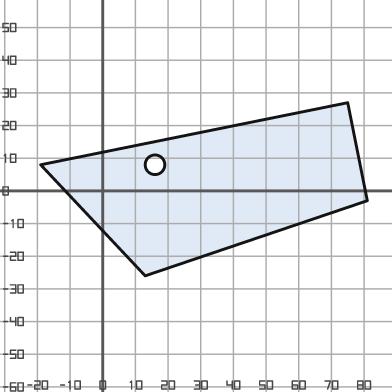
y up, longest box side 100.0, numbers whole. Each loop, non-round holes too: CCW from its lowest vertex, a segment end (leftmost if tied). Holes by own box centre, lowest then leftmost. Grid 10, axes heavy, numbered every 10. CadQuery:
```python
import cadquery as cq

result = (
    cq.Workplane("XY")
    .moveTo(13.0, -26.0)
    .lineTo(81.0, -3.0)
    .lineTo(75.0, 27.0)
    .lineTo(-19.0, 8.0)
    .close()
    .moveTo(16.0, 8.0)
    .circle(3.0)
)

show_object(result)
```